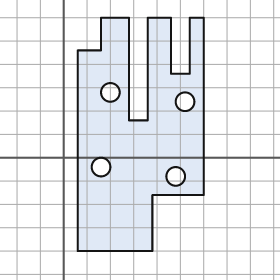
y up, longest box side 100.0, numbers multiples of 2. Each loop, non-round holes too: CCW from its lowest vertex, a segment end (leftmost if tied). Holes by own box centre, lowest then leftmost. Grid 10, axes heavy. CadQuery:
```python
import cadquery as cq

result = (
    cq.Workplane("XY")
    .moveTo(6.0, -40.0)
    .lineTo(38.0, -40.0)
    .lineTo(38.0, -16.0)
    .lineTo(60.0, -16.0)
    .lineTo(60.0, 60.0)
    .lineTo(54.0, 60.0)
    .lineTo(54.0, 36.0)
    .lineTo(46.0, 36.0)
    .lineTo(46.0, 60.0)
    .lineTo(36.0, 60.0)
    .lineTo(36.0, 16.0)
    .lineTo(28.0, 16.0)
    .lineTo(28.0, 60.0)
    .lineTo(16.0, 60.0)
    .lineTo(16.0, 46.0)
    .lineTo(6.0, 46.0)
    .close()
    .moveTo(48.0, -8.0)
    .circle(4.0)
    .moveTo(16.0, -4.0)
    .circle(4.0)
    .moveTo(52.0, 24.0)
    .circle(4.0)
    .moveTo(20.0, 28.0)
    .circle(4.0)
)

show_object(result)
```